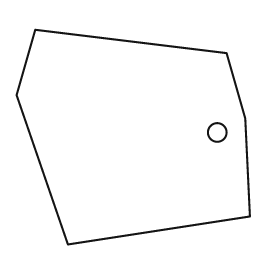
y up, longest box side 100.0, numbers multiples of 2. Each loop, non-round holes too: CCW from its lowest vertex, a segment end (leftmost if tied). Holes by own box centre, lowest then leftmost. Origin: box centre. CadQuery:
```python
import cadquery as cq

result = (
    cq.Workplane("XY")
    .moveTo(-28.0, -46.0)
    .lineTo(50.0, -34.0)
    .lineTo(48.0, 8.0)
    .lineTo(40.0, 36.0)
    .lineTo(-42.0, 46.0)
    .lineTo(-50.0, 18.0)
    .close()
    .moveTo(36.0, 2.0)
    .circle(4.0)
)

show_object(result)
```